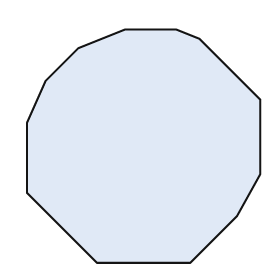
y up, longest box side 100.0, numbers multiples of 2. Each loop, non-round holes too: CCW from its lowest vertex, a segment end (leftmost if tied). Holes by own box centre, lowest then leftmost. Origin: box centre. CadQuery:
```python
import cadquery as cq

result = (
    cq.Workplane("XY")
    .moveTo(-20.0, -50.0)
    .lineTo(20.0, -50.0)
    .lineTo(40.0, -30.0)
    .lineTo(50.0, -12.0)
    .lineTo(50.0, 20.0)
    .lineTo(24.0, 46.0)
    .lineTo(14.0, 50.0)
    .lineTo(-8.0, 50.0)
    .lineTo(-28.0, 42.0)
    .lineTo(-42.0, 28.0)
    .lineTo(-50.0, 10.0)
    .lineTo(-50.0, -20.0)
    .close()
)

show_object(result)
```